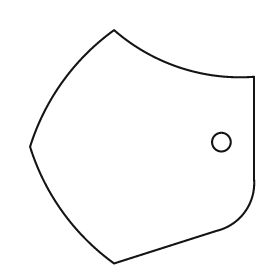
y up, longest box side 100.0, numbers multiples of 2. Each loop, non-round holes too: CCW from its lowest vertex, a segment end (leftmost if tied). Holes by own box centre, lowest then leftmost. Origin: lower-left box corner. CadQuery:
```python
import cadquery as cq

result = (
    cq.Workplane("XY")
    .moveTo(36.0, 0.0)
    .lineTo(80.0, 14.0)
    .threePointArc((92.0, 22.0), (96.0, 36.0))
    .lineTo(96.0, 80.0)
    .threePointArc((64.0, 84.0), (36.0, 100.0))
    .threePointArc((14.0, 78.0), (0.0, 50.0))
    .threePointArc((14.0, 22.0), (36.0, 0.0))
    .close()
    .moveTo(82.0, 52.0)
    .circle(4.0)
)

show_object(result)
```